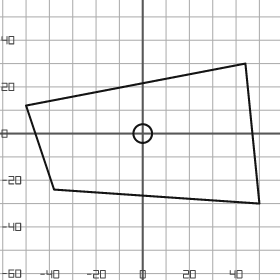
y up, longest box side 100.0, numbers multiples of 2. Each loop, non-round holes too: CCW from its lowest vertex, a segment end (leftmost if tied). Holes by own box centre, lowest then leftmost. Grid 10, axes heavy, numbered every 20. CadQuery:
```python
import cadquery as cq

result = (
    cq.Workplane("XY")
    .moveTo(50.0, -30.0)
    .lineTo(44.0, 30.0)
    .lineTo(-50.0, 12.0)
    .lineTo(-38.0, -24.0)
    .close()
    .moveTo(0.0, 0.0)
    .circle(4.0)
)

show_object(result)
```